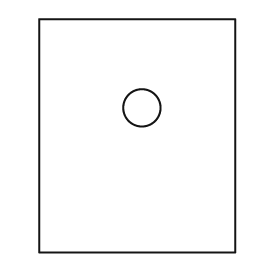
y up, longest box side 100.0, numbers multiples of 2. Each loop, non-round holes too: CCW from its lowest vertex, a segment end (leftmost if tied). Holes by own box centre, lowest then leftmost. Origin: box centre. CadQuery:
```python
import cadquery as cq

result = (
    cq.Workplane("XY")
    .moveTo(-42.0, -50.0)
    .lineTo(42.0, -50.0)
    .lineTo(42.0, 50.0)
    .lineTo(-42.0, 50.0)
    .close()
    .moveTo(2.0, 12.0)
    .circle(8.0)
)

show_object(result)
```